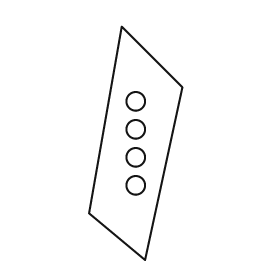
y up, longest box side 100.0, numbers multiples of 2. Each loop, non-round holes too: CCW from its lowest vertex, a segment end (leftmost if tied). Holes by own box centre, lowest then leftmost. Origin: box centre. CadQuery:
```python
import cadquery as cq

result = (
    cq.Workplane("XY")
    .moveTo(4.0, -50.0)
    .lineTo(20.0, 24.0)
    .lineTo(-6.0, 50.0)
    .lineTo(-20.0, -30.0)
    .close()
    .moveTo(0.0, -18.0)
    .circle(4.0)
    .moveTo(0.0, -6.0)
    .circle(4.0)
    .moveTo(0.0, 6.0)
    .circle(4.0)
    .moveTo(0.0, 18.0)
    .circle(4.0)
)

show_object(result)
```